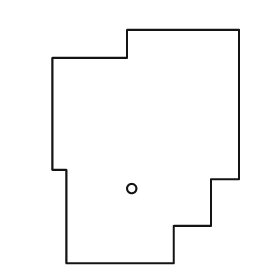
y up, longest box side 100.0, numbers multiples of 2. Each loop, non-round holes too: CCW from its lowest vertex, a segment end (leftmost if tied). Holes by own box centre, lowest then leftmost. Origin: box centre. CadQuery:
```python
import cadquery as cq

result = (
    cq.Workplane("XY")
    .moveTo(-34.0, -50.0)
    .lineTo(12.0, -50.0)
    .lineTo(12.0, -34.0)
    .lineTo(28.0, -34.0)
    .lineTo(28.0, -14.0)
    .lineTo(40.0, -14.0)
    .lineTo(40.0, 50.0)
    .lineTo(-8.0, 50.0)
    .lineTo(-8.0, 38.0)
    .lineTo(-40.0, 38.0)
    .lineTo(-40.0, -10.0)
    .lineTo(-34.0, -10.0)
    .close()
    .moveTo(-6.0, -18.0)
    .circle(2.0)
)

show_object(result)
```